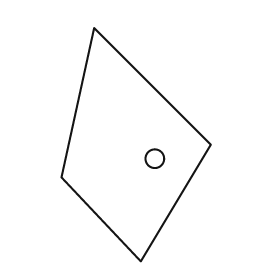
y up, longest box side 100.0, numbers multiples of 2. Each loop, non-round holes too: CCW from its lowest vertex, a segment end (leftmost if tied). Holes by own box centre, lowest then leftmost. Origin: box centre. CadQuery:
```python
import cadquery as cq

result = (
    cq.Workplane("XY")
    .moveTo(2.0, -50.0)
    .lineTo(32.0, 0.0)
    .lineTo(-18.0, 50.0)
    .lineTo(-32.0, -14.0)
    .close()
    .moveTo(8.0, -6.0)
    .circle(4.0)
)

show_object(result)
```